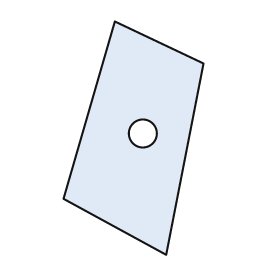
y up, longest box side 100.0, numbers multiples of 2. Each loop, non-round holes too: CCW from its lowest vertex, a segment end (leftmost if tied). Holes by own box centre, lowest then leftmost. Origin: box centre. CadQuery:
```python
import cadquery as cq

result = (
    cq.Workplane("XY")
    .moveTo(14.0, -50.0)
    .lineTo(30.0, 32.0)
    .lineTo(-8.0, 50.0)
    .lineTo(-30.0, -26.0)
    .close()
    .moveTo(4.0, 2.0)
    .circle(6.0)
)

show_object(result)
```